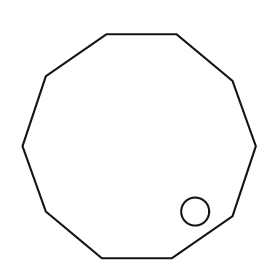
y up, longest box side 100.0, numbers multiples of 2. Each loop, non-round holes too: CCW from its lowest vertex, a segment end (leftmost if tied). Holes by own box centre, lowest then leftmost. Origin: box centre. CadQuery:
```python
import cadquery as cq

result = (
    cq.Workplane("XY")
    .moveTo(-16.0, -48.0)
    .lineTo(14.0, -48.0)
    .lineTo(40.0, -30.0)
    .lineTo(50.0, 0.0)
    .lineTo(40.0, 28.0)
    .lineTo(16.0, 48.0)
    .lineTo(-14.0, 48.0)
    .lineTo(-40.0, 30.0)
    .lineTo(-50.0, 0.0)
    .lineTo(-40.0, -28.0)
    .close()
    .moveTo(24.0, -28.0)
    .circle(6.0)
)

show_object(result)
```